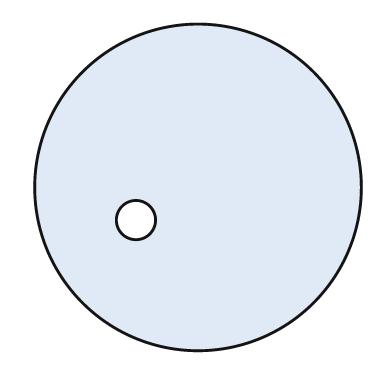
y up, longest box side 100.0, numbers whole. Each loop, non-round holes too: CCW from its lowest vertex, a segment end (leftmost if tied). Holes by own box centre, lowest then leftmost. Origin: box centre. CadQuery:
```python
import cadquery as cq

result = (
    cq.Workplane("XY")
    .moveTo(0.0, 0.0)
    .circle(50.0)
    .moveTo(-19.0, -10.0)
    .circle(6.0)
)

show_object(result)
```